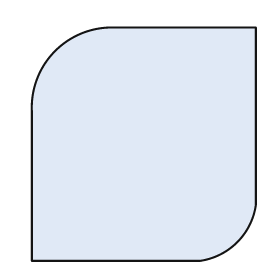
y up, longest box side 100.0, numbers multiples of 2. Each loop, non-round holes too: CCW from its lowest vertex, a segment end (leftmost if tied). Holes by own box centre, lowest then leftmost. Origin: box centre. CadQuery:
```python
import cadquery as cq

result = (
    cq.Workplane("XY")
    .moveTo(-48.0, -50.0)
    .lineTo(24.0, -50.0)
    .threePointArc((40.0, -42.0), (48.0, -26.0))
    .lineTo(48.0, 50.0)
    .lineTo(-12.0, 50.0)
    .threePointArc((-38.0, 40.0), (-48.0, 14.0))
    .close()
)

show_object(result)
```